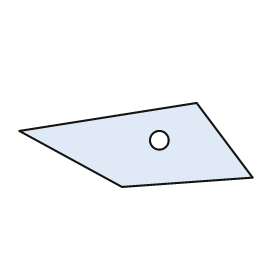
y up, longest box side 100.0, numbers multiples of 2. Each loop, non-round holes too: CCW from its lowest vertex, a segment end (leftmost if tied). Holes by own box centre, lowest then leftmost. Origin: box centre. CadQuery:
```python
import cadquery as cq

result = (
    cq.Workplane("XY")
    .moveTo(-6.0, -18.0)
    .lineTo(50.0, -14.0)
    .lineTo(26.0, 18.0)
    .lineTo(-50.0, 6.0)
    .close()
    .moveTo(10.0, 2.0)
    .circle(4.0)
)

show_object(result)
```